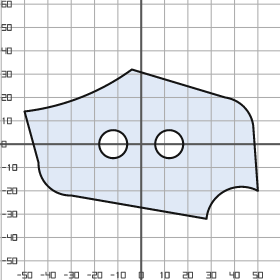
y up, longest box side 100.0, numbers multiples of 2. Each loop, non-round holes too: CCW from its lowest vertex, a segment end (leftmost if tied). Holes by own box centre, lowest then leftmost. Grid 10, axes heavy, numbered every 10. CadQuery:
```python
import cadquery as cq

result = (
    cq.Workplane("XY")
    .moveTo(28.0, -32.0)
    .threePointArc((36.0, -20.0), (50.0, -20.0))
    .lineTo(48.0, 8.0)
    .threePointArc((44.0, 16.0), (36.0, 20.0))
    .lineTo(-4.0, 32.0)
    .threePointArc((-26.0, 20.0), (-50.0, 14.0))
    .lineTo(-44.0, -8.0)
    .threePointArc((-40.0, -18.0), (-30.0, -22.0))
    .close()
    .moveTo(-12.0, 0.0)
    .circle(6.0)
    .moveTo(12.0, 0.0)
    .circle(6.0)
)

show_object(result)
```